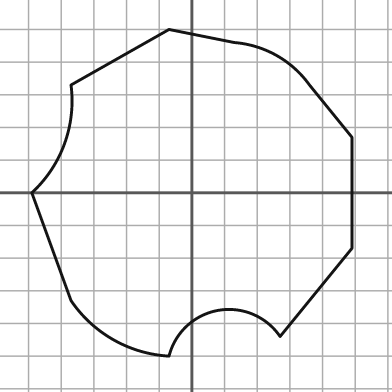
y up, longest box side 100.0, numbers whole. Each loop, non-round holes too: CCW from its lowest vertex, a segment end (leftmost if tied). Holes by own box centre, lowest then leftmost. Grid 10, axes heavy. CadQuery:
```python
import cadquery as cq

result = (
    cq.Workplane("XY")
    .moveTo(-7.0, -50.0)
    .threePointArc((8.0, -36.0), (27.0, -44.0))
    .lineTo(49.0, -17.0)
    .lineTo(49.0, 17.0)
    .lineTo(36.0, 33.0)
    .threePointArc((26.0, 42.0), (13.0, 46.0))
    .lineTo(-7.0, 50.0)
    .lineTo(-37.0, 33.0)
    .threePointArc((-39.0, 15.0), (-49.0, 0.0))
    .lineTo(-37.0, -33.0)
    .threePointArc((-24.0, -45.0), (-7.0, -50.0))
    .close()
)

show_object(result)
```